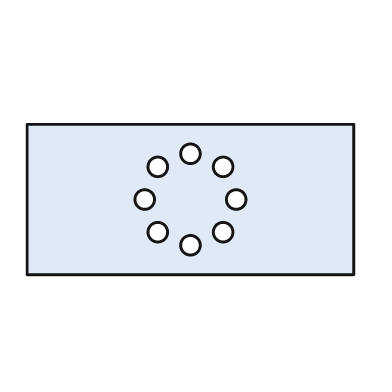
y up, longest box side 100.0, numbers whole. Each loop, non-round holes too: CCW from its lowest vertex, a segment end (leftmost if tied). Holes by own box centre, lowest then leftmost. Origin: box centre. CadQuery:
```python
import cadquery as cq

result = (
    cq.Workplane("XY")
    .moveTo(-50.0, -23.0)
    .lineTo(50.0, -23.0)
    .lineTo(50.0, 23.0)
    .lineTo(-50.0, 23.0)
    .close()
    .moveTo(0.0, -14.0)
    .circle(3.0)
    .moveTo(-10.0, -10.0)
    .circle(3.0)
    .moveTo(10.0, -10.0)
    .circle(3.0)
    .moveTo(-14.0, 0.0)
    .circle(3.0)
    .moveTo(14.0, 0.0)
    .circle(3.0)
    .moveTo(-10.0, 10.0)
    .circle(3.0)
    .moveTo(10.0, 10.0)
    .circle(3.0)
    .moveTo(0.0, 14.0)
    .circle(3.0)
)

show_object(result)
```